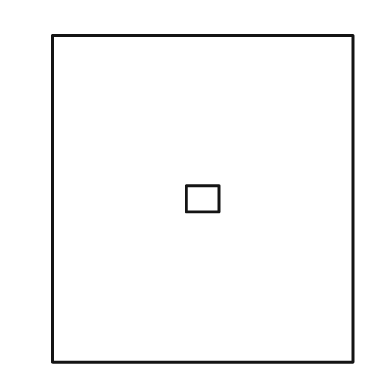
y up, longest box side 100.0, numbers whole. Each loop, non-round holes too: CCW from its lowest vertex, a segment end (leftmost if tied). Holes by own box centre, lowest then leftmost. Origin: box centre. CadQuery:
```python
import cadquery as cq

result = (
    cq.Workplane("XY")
    .moveTo(-46.0, -50.0)
    .lineTo(46.0, -50.0)
    .lineTo(46.0, 50.0)
    .lineTo(-46.0, 50.0)
    .close()
    .moveTo(-5.0, -4.0)
    .lineTo(5.0, -4.0)
    .lineTo(5.0, 4.0)
    .lineTo(-5.0, 4.0)
    .close()
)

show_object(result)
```